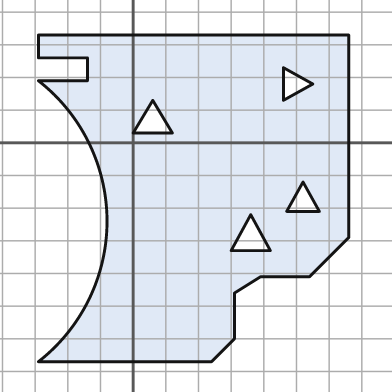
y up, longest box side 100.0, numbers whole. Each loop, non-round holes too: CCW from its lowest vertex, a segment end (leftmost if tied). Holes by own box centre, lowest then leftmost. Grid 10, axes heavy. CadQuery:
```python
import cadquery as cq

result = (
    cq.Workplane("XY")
    .moveTo(-29.0, -67.0)
    .lineTo(24.0, -67.0)
    .lineTo(31.0, -60.0)
    .lineTo(31.0, -46.0)
    .lineTo(39.0, -41.0)
    .lineTo(54.0, -41.0)
    .lineTo(66.0, -29.0)
    .lineTo(66.0, 33.0)
    .lineTo(-29.0, 33.0)
    .lineTo(-29.0, 26.0)
    .lineTo(-14.0, 26.0)
    .lineTo(-14.0, 19.0)
    .lineTo(-29.0, 19.0)
    .threePointArc((-8.0, -24.0), (-29.0, -67.0))
    .close()
    .moveTo(30.0, -33.0)
    .lineTo(42.0, -33.0)
    .lineTo(36.0, -22.0)
    .close()
    .moveTo(47.0, -21.0)
    .lineTo(57.0, -21.0)
    .lineTo(52.0, -12.0)
    .close()
    .moveTo(0.0, 3.0)
    .lineTo(12.0, 3.0)
    .lineTo(6.0, 13.0)
    .close()
    .moveTo(46.0, 13.0)
    .lineTo(55.0, 18.0)
    .lineTo(46.0, 23.0)
    .close()
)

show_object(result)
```